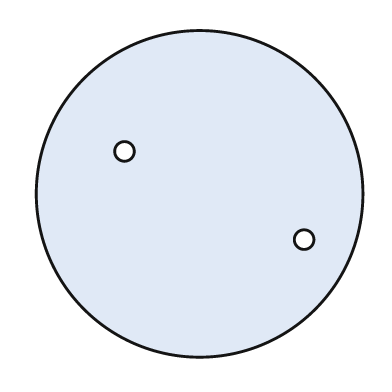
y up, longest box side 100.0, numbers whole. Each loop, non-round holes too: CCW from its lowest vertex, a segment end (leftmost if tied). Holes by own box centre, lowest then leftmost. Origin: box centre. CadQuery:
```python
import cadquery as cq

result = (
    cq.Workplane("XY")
    .moveTo(0.0, 0.0)
    .circle(50.0)
    .moveTo(32.0, -14.0)
    .circle(3.0)
    .moveTo(-23.0, 13.0)
    .circle(3.0)
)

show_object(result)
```